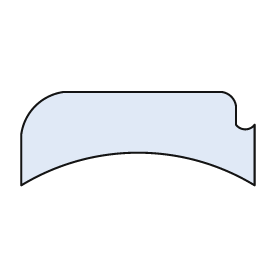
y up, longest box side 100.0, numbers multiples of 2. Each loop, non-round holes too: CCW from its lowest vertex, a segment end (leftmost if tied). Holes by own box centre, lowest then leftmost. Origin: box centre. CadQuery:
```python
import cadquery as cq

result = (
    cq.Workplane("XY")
    .moveTo(-50.0, -20.0)
    .threePointArc((0.0, -6.0), (50.0, -20.0))
    .lineTo(50.0, 6.0)
    .threePointArc((46.0, 4.0), (42.0, 6.0))
    .lineTo(42.0, 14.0)
    .threePointArc((40.0, 18.0), (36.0, 20.0))
    .lineTo(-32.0, 20.0)
    .threePointArc((-44.0, 14.0), (-50.0, 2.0))
    .close()
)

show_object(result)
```